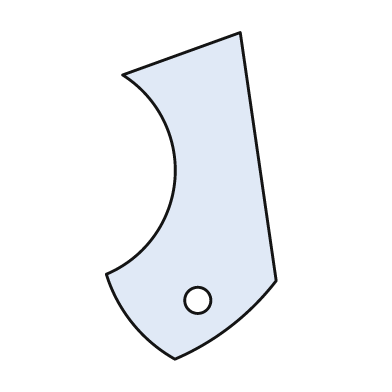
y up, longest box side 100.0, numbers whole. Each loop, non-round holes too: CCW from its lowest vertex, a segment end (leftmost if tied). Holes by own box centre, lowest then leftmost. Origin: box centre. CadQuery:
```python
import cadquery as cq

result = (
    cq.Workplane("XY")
    .moveTo(-5.0, -50.0)
    .threePointArc((12.0, -40.0), (26.0, -26.0))
    .lineTo(15.0, 50.0)
    .lineTo(-21.0, 37.0)
    .threePointArc((-5.0, 5.0), (-26.0, -24.0))
    .threePointArc((-18.0, -39.0), (-5.0, -50.0))
    .close()
    .moveTo(2.0, -32.0)
    .circle(4.0)
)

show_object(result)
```